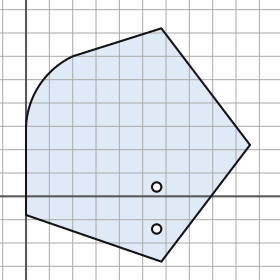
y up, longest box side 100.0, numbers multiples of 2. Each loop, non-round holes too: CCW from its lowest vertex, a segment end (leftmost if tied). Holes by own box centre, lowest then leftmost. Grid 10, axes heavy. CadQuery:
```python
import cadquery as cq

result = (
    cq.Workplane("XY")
    .moveTo(58.0, -28.0)
    .lineTo(96.0, 22.0)
    .lineTo(58.0, 72.0)
    .lineTo(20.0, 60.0)
    .threePointArc((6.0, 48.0), (0.0, 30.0))
    .lineTo(0.0, -8.0)
    .close()
    .moveTo(56.0, -14.0)
    .circle(2.0)
    .moveTo(56.0, 4.0)
    .circle(2.0)
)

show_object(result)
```